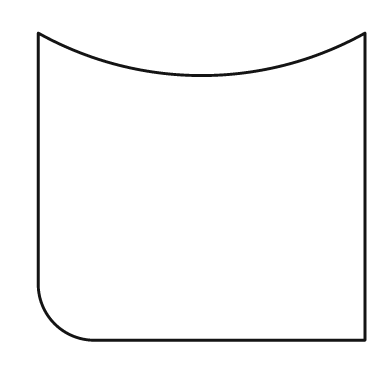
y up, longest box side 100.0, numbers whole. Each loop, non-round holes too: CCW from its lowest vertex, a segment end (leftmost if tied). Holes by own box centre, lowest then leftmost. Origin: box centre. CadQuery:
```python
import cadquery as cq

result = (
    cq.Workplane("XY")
    .moveTo(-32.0, -47.0)
    .lineTo(50.0, -47.0)
    .lineTo(50.0, 47.0)
    .threePointArc((0.0, 34.0), (-50.0, 47.0))
    .lineTo(-50.0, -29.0)
    .threePointArc((-45.0, -42.0), (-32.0, -47.0))
    .close()
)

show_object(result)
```